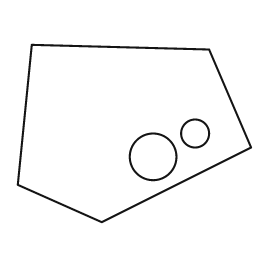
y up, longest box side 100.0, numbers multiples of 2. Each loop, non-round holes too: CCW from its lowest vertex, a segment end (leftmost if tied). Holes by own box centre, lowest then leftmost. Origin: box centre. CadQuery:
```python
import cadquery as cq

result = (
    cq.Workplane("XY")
    .moveTo(-14.0, -38.0)
    .lineTo(50.0, -6.0)
    .lineTo(32.0, 36.0)
    .lineTo(-44.0, 38.0)
    .lineTo(-50.0, -22.0)
    .close()
    .moveTo(8.0, -10.0)
    .circle(10.0)
    .moveTo(26.0, 0.0)
    .circle(6.0)
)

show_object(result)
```